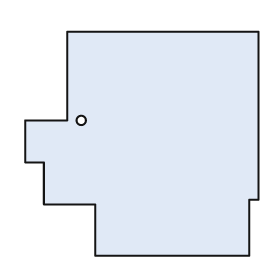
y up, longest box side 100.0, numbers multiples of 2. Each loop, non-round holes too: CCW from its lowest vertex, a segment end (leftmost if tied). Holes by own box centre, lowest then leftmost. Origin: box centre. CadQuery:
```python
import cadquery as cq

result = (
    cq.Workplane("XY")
    .moveTo(-20.0, -48.0)
    .lineTo(46.0, -48.0)
    .lineTo(46.0, -24.0)
    .lineTo(50.0, -24.0)
    .lineTo(50.0, 48.0)
    .lineTo(-32.0, 48.0)
    .lineTo(-32.0, 10.0)
    .lineTo(-50.0, 10.0)
    .lineTo(-50.0, -8.0)
    .lineTo(-42.0, -8.0)
    .lineTo(-42.0, -26.0)
    .lineTo(-20.0, -26.0)
    .close()
    .moveTo(-26.0, 10.0)
    .circle(2.0)
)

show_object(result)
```